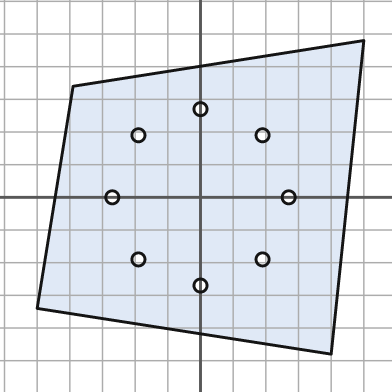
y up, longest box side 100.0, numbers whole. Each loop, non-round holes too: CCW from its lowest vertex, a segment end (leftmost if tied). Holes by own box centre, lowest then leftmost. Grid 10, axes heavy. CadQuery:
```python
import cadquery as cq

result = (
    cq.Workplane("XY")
    .moveTo(40.0, -48.0)
    .lineTo(50.0, 48.0)
    .lineTo(-39.0, 34.0)
    .lineTo(-50.0, -34.0)
    .close()
    .moveTo(0.0, -27.0)
    .circle(2.0)
    .moveTo(-19.0, -19.0)
    .circle(2.0)
    .moveTo(19.0, -19.0)
    .circle(2.0)
    .moveTo(-27.0, 0.0)
    .circle(2.0)
    .moveTo(27.0, 0.0)
    .circle(2.0)
    .moveTo(-19.0, 19.0)
    .circle(2.0)
    .moveTo(19.0, 19.0)
    .circle(2.0)
    .moveTo(0.0, 27.0)
    .circle(2.0)
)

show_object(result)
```